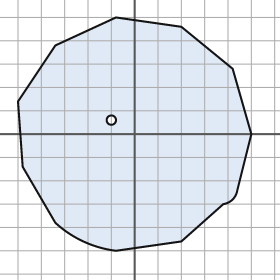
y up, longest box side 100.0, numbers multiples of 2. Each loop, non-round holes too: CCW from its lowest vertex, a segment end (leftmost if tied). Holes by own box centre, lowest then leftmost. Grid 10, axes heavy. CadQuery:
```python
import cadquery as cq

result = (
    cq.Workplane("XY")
    .moveTo(-8.0, -50.0)
    .lineTo(20.0, -46.0)
    .lineTo(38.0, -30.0)
    .threePointArc((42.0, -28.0), (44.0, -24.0))
    .lineTo(50.0, 0.0)
    .lineTo(42.0, 28.0)
    .lineTo(20.0, 46.0)
    .lineTo(-8.0, 50.0)
    .lineTo(-34.0, 38.0)
    .lineTo(-50.0, 14.0)
    .lineTo(-48.0, -14.0)
    .lineTo(-34.0, -38.0)
    .threePointArc((-22.0, -46.0), (-8.0, -50.0))
    .close()
    .moveTo(-10.0, 6.0)
    .circle(2.0)
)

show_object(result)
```